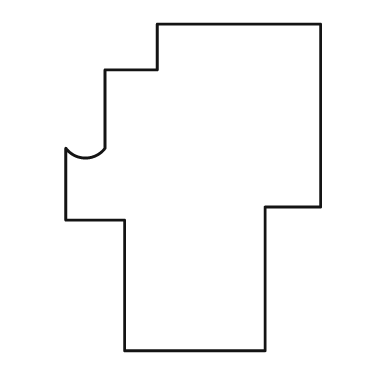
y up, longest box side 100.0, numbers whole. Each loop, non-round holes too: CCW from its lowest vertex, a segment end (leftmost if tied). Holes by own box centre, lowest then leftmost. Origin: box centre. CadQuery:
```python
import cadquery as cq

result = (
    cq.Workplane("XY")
    .moveTo(-21.0, -50.0)
    .lineTo(22.0, -50.0)
    .lineTo(22.0, -6.0)
    .lineTo(39.0, -6.0)
    .lineTo(39.0, 50.0)
    .lineTo(-11.0, 50.0)
    .lineTo(-11.0, 36.0)
    .lineTo(-27.0, 36.0)
    .lineTo(-27.0, 12.0)
    .threePointArc((-33.0, 9.0), (-39.0, 12.0))
    .lineTo(-39.0, -10.0)
    .lineTo(-21.0, -10.0)
    .close()
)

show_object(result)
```